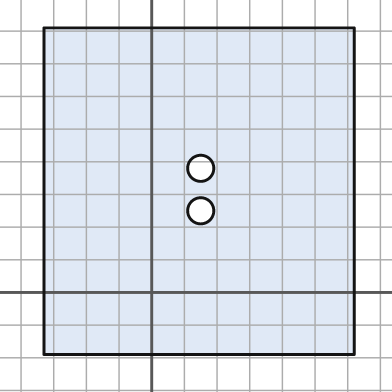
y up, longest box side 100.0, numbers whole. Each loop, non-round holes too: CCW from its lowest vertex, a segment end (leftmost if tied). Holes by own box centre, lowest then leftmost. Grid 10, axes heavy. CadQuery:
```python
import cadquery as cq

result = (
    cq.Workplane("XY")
    .moveTo(-33.0, -19.0)
    .lineTo(62.0, -19.0)
    .lineTo(62.0, 81.0)
    .lineTo(-33.0, 81.0)
    .close()
    .moveTo(15.0, 25.0)
    .circle(4.0)
    .moveTo(15.0, 38.0)
    .circle(4.0)
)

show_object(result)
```